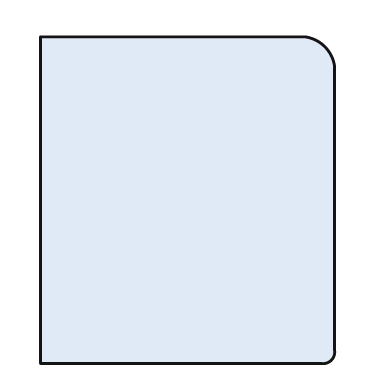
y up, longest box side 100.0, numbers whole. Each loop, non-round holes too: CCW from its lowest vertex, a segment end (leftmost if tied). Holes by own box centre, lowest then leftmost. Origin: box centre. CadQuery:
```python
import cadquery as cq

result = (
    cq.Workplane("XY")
    .moveTo(-45.0, -50.0)
    .lineTo(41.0, -50.0)
    .threePointArc((44.0, -49.0), (45.0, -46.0))
    .lineTo(45.0, 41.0)
    .threePointArc((42.0, 47.0), (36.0, 50.0))
    .lineTo(-45.0, 50.0)
    .close()
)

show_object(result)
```